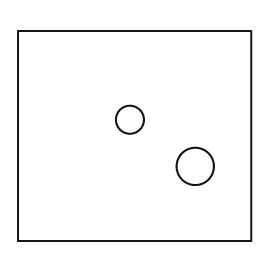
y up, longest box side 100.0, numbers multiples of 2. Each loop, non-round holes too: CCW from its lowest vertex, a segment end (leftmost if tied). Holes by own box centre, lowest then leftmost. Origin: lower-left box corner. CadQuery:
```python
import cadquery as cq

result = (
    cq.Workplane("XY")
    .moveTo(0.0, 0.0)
    .lineTo(100.0, 0.0)
    .lineTo(100.0, 90.0)
    .lineTo(0.0, 90.0)
    .close()
    .moveTo(76.0, 32.0)
    .circle(8.0)
    .moveTo(48.0, 52.0)
    .circle(6.0)
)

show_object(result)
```